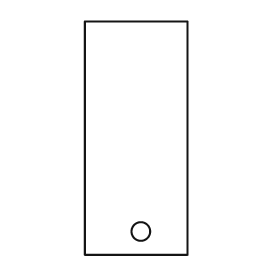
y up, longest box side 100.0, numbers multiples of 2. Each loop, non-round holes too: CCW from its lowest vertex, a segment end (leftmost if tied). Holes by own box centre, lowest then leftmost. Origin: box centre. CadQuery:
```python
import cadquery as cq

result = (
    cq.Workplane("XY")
    .moveTo(-22.0, -50.0)
    .lineTo(22.0, -50.0)
    .lineTo(22.0, 50.0)
    .lineTo(-22.0, 50.0)
    .close()
    .moveTo(2.0, -40.0)
    .circle(4.0)
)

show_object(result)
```